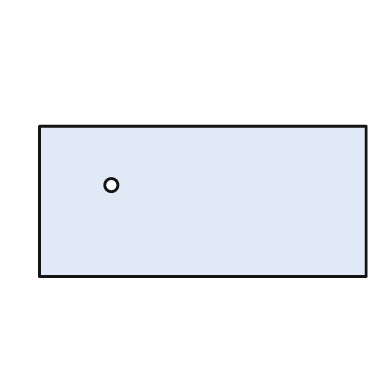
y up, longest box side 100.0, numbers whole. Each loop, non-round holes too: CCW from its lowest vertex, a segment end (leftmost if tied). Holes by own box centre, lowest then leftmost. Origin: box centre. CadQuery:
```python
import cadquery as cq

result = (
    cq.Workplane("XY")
    .moveTo(-50.0, -23.0)
    .lineTo(50.0, -23.0)
    .lineTo(50.0, 23.0)
    .lineTo(-50.0, 23.0)
    .close()
    .moveTo(-28.0, 5.0)
    .circle(2.0)
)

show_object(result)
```